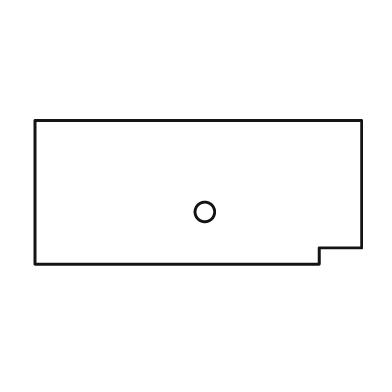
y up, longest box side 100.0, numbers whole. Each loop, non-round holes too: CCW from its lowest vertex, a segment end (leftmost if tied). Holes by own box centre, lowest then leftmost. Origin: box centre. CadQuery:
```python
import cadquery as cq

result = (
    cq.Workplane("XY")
    .moveTo(-50.0, -22.0)
    .lineTo(37.0, -22.0)
    .lineTo(37.0, -17.0)
    .lineTo(50.0, -17.0)
    .lineTo(50.0, 22.0)
    .lineTo(-50.0, 22.0)
    .close()
    .moveTo(2.0, -6.0)
    .circle(3.0)
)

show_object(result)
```